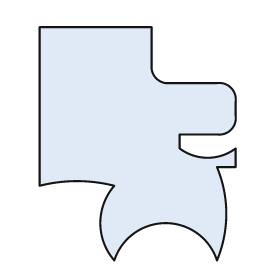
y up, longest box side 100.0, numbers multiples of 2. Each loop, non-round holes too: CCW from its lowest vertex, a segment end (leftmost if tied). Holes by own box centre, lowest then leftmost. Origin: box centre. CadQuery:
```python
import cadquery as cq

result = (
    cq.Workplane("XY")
    .moveTo(-10.0, -50.0)
    .threePointArc((12.0, -34.0), (34.0, -50.0))
    .threePointArc((38.0, -30.0), (34.0, -10.0))
    .lineTo(42.0, -10.0)
    .lineTo(42.0, -2.0)
    .threePointArc((30.0, -6.0), (18.0, -2.0))
    .lineTo(18.0, 4.0)
    .lineTo(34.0, 4.0)
    .threePointArc((40.0, 6.0), (42.0, 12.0))
    .lineTo(42.0, 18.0)
    .threePointArc((40.0, 24.0), (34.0, 26.0))
    .lineTo(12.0, 26.0)
    .threePointArc((8.0, 28.0), (6.0, 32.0))
    .lineTo(6.0, 50.0)
    .lineTo(-42.0, 50.0)
    .lineTo(-42.0, -18.0)
    .threePointArc((-26.0, -16.0), (-10.0, -18.0))
    .threePointArc((-16.0, -34.0), (-10.0, -50.0))
    .close()
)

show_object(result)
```